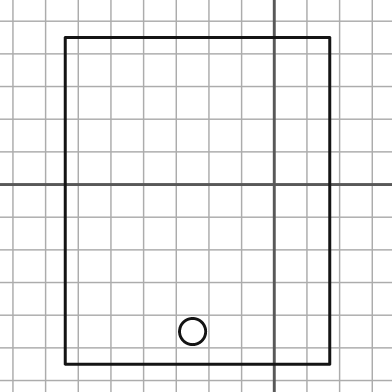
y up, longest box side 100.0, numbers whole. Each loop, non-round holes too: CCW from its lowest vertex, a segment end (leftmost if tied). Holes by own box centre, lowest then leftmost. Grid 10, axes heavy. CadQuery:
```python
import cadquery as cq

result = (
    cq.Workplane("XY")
    .moveTo(-64.0, -55.0)
    .lineTo(17.0, -55.0)
    .lineTo(17.0, 45.0)
    .lineTo(-64.0, 45.0)
    .close()
    .moveTo(-25.0, -45.0)
    .circle(4.0)
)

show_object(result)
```